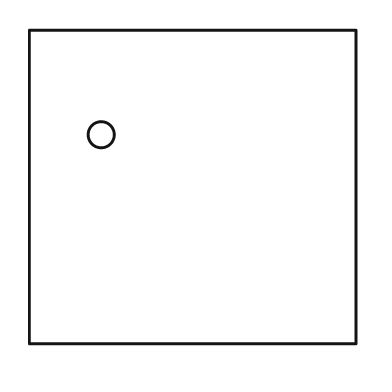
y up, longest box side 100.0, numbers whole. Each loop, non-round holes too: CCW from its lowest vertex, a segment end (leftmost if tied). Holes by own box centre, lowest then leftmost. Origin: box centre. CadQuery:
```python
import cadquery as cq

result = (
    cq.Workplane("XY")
    .moveTo(-50.0, -48.0)
    .lineTo(50.0, -48.0)
    .lineTo(50.0, 48.0)
    .lineTo(-50.0, 48.0)
    .close()
    .moveTo(-28.0, 16.0)
    .circle(4.0)
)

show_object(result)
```